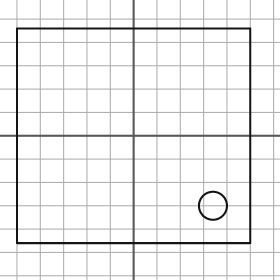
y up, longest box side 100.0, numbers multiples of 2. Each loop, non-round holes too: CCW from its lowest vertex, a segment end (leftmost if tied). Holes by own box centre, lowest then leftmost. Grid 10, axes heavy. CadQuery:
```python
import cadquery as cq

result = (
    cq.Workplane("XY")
    .moveTo(-50.0, -46.0)
    .lineTo(50.0, -46.0)
    .lineTo(50.0, 46.0)
    .lineTo(-50.0, 46.0)
    .close()
    .moveTo(34.0, -30.0)
    .circle(6.0)
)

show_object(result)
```